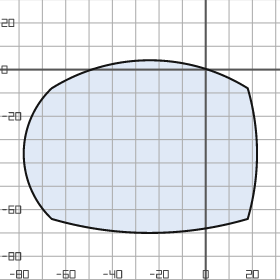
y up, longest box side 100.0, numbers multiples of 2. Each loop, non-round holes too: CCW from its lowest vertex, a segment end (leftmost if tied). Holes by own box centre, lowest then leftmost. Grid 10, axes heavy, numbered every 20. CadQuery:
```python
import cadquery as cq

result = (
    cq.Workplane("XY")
    .moveTo(-66.0, -64.0)
    .threePointArc((-24.0, -70.0), (18.0, -64.0))
    .threePointArc((22.0, -36.0), (18.0, -8.0))
    .threePointArc((-24.0, 4.0), (-66.0, -8.0))
    .threePointArc((-78.0, -36.0), (-66.0, -64.0))
    .close()
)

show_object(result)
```